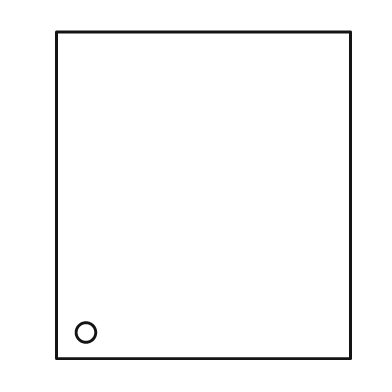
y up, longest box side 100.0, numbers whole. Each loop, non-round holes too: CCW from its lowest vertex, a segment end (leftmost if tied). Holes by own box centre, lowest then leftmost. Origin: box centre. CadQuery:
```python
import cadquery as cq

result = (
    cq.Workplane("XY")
    .moveTo(-45.0, -50.0)
    .lineTo(45.0, -50.0)
    .lineTo(45.0, 50.0)
    .lineTo(-45.0, 50.0)
    .close()
    .moveTo(-36.0, -42.0)
    .circle(3.0)
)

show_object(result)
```